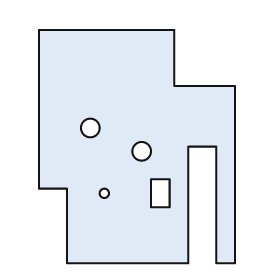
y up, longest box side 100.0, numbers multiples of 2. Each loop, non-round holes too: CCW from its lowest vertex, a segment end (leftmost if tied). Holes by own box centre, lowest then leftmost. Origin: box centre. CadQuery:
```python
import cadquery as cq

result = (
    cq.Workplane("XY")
    .moveTo(-30.0, -50.0)
    .lineTo(22.0, -50.0)
    .lineTo(22.0, 0.0)
    .lineTo(34.0, 0.0)
    .lineTo(34.0, -50.0)
    .lineTo(42.0, -50.0)
    .lineTo(42.0, 26.0)
    .lineTo(16.0, 26.0)
    .lineTo(16.0, 50.0)
    .lineTo(-42.0, 50.0)
    .lineTo(-42.0, -18.0)
    .lineTo(-30.0, -18.0)
    .close()
    .moveTo(-14.0, -20.0)
    .circle(2.0)
    .moveTo(6.0, -26.0)
    .lineTo(14.0, -26.0)
    .lineTo(14.0, -14.0)
    .lineTo(6.0, -14.0)
    .close()
    .moveTo(2.0, -2.0)
    .circle(4.0)
    .moveTo(-20.0, 8.0)
    .circle(4.0)
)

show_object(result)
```